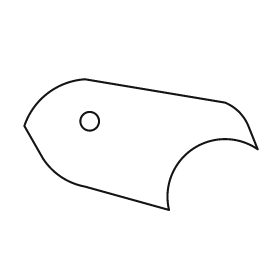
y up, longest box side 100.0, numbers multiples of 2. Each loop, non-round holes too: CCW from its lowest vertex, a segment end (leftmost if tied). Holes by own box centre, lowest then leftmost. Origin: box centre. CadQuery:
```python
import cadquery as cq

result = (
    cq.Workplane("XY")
    .moveTo(12.0, -28.0)
    .threePointArc((22.0, -2.0), (50.0, -2.0))
    .lineTo(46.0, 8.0)
    .threePointArc((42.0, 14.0), (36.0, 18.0))
    .lineTo(-24.0, 28.0)
    .threePointArc((-40.0, 22.0), (-50.0, 8.0))
    .lineTo(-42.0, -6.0)
    .threePointArc((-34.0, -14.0), (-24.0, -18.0))
    .close()
    .moveTo(-22.0, 10.0)
    .circle(4.0)
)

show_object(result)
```